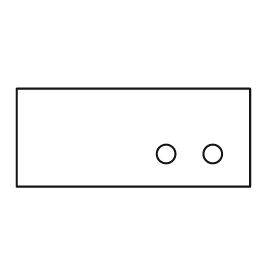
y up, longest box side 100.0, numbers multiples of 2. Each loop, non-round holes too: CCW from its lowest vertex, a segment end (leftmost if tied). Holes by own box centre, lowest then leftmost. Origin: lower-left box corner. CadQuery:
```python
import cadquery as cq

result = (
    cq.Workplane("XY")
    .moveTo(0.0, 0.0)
    .lineTo(100.0, 0.0)
    .lineTo(100.0, 42.0)
    .lineTo(0.0, 42.0)
    .close()
    .moveTo(64.0, 14.0)
    .circle(4.0)
    .moveTo(84.0, 14.0)
    .circle(4.0)
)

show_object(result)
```